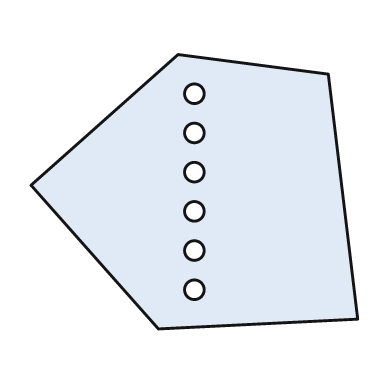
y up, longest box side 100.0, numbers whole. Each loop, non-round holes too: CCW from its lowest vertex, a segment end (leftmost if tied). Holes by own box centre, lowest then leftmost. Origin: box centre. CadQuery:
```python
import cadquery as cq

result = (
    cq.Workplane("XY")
    .moveTo(-11.0, -42.0)
    .lineTo(50.0, -39.0)
    .lineTo(41.0, 36.0)
    .lineTo(-5.0, 42.0)
    .lineTo(-50.0, 2.0)
    .close()
    .moveTo(0.0, -30.0)
    .circle(3.0)
    .moveTo(0.0, -18.0)
    .circle(3.0)
    .moveTo(0.0, -6.0)
    .circle(3.0)
    .moveTo(0.0, 6.0)
    .circle(3.0)
    .moveTo(0.0, 18.0)
    .circle(3.0)
    .moveTo(0.0, 30.0)
    .circle(3.0)
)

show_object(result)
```